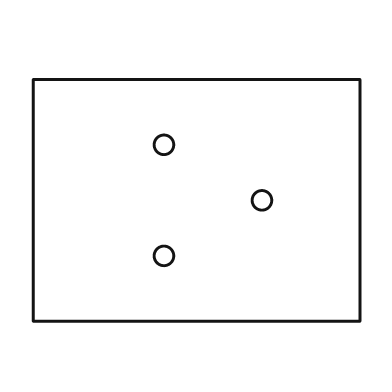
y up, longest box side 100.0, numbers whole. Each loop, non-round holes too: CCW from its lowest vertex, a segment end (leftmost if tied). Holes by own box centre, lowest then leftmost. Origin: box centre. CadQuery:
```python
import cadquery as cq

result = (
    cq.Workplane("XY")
    .moveTo(-50.0, -37.0)
    .lineTo(50.0, -37.0)
    .lineTo(50.0, 37.0)
    .lineTo(-50.0, 37.0)
    .close()
    .moveTo(-10.0, -17.0)
    .circle(3.0)
    .moveTo(20.0, 0.0)
    .circle(3.0)
    .moveTo(-10.0, 17.0)
    .circle(3.0)
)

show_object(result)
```